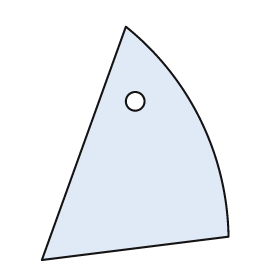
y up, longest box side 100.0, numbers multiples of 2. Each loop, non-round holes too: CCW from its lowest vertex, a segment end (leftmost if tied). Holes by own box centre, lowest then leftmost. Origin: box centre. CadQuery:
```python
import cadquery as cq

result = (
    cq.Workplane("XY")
    .moveTo(-40.0, -50.0)
    .lineTo(40.0, -40.0)
    .threePointArc((28.0, 10.0), (-4.0, 50.0))
    .close()
    .moveTo(0.0, 18.0)
    .circle(4.0)
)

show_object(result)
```